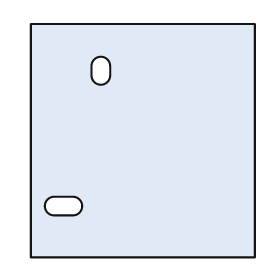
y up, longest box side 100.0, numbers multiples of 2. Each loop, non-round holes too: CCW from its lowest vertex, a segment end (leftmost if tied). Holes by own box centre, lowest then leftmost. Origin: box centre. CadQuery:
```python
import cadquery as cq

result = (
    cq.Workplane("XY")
    .moveTo(-48.0, -50.0)
    .lineTo(48.0, -50.0)
    .lineTo(48.0, 50.0)
    .lineTo(-48.0, 50.0)
    .close()
    .moveTo(-38.0, -32.0)
    .lineTo(-30.0, -32.0)
    .threePointArc((-26.0, -28.0), (-30.0, -24.0))
    .lineTo(-38.0, -24.0)
    .threePointArc((-42.0, -28.0), (-38.0, -32.0))
    .close()
    .moveTo(-22.0, 28.0)
    .threePointArc((-18.0, 24.0), (-14.0, 28.0))
    .lineTo(-14.0, 32.0)
    .threePointArc((-18.0, 36.0), (-22.0, 32.0))
    .close()
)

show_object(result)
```